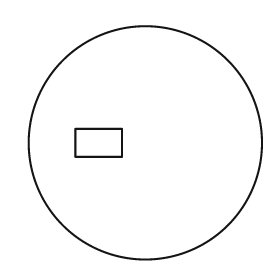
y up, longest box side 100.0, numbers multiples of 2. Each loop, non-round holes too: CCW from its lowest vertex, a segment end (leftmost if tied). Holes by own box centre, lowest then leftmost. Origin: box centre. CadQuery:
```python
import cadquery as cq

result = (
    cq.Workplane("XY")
    .moveTo(0.0, 0.0)
    .circle(50.0)
    .moveTo(-30.0, -6.0)
    .lineTo(-10.0, -6.0)
    .lineTo(-10.0, 6.0)
    .lineTo(-30.0, 6.0)
    .close()
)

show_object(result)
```